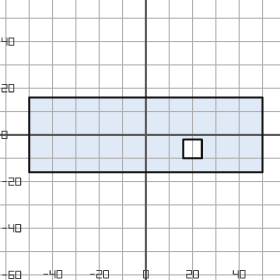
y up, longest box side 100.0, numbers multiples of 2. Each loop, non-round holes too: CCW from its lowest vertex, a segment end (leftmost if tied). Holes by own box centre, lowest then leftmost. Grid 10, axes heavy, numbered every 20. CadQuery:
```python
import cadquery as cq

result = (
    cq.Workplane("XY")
    .moveTo(-50.0, -16.0)
    .lineTo(50.0, -16.0)
    .lineTo(50.0, 16.0)
    .lineTo(-50.0, 16.0)
    .close()
    .moveTo(16.0, -10.0)
    .lineTo(24.0, -10.0)
    .lineTo(24.0, -2.0)
    .lineTo(16.0, -2.0)
    .close()
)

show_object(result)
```